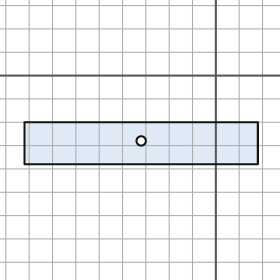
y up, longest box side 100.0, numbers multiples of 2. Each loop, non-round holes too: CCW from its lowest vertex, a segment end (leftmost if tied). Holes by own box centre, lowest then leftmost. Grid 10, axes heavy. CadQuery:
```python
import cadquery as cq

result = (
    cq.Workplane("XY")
    .moveTo(-82.0, -38.0)
    .lineTo(18.0, -38.0)
    .lineTo(18.0, -20.0)
    .lineTo(-82.0, -20.0)
    .close()
    .moveTo(-32.0, -28.0)
    .circle(2.0)
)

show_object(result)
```